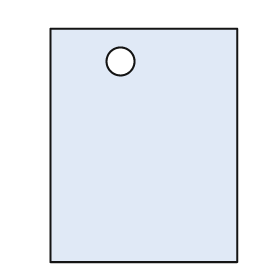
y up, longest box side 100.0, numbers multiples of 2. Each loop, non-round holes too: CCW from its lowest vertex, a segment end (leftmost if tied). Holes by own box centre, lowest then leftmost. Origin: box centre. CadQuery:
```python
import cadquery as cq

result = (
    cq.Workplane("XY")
    .moveTo(-40.0, -50.0)
    .lineTo(40.0, -50.0)
    .lineTo(40.0, 50.0)
    .lineTo(-40.0, 50.0)
    .close()
    .moveTo(-10.0, 36.0)
    .circle(6.0)
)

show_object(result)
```